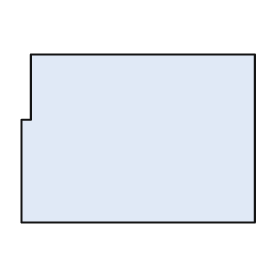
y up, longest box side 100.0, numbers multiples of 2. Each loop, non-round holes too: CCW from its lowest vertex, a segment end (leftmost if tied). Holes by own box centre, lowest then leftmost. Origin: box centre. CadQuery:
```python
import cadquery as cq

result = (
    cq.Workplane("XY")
    .moveTo(-50.0, -36.0)
    .lineTo(50.0, -36.0)
    .lineTo(50.0, 36.0)
    .lineTo(-46.0, 36.0)
    .lineTo(-46.0, 8.0)
    .lineTo(-50.0, 8.0)
    .close()
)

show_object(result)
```